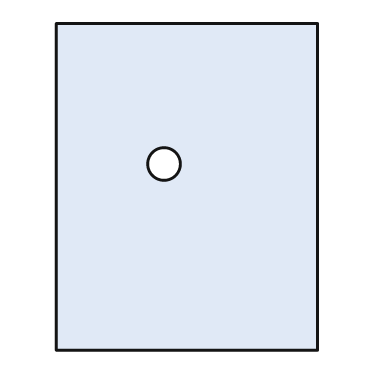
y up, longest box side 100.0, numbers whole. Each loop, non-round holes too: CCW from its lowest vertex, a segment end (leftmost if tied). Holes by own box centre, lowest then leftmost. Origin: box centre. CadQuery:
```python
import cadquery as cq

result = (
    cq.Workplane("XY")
    .moveTo(-40.0, -50.0)
    .lineTo(40.0, -50.0)
    .lineTo(40.0, 50.0)
    .lineTo(-40.0, 50.0)
    .close()
    .moveTo(-7.0, 7.0)
    .circle(5.0)
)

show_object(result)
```